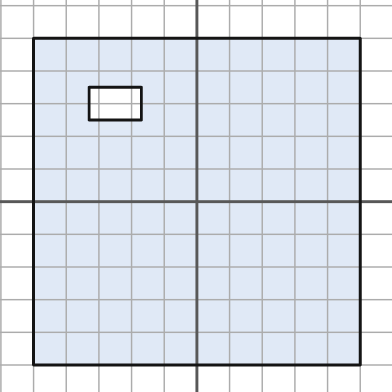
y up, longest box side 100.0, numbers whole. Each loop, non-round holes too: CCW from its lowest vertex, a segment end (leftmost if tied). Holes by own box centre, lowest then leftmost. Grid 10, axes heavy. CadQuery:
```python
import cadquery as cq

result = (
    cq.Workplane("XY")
    .moveTo(-50.0, -50.0)
    .lineTo(50.0, -50.0)
    .lineTo(50.0, 50.0)
    .lineTo(-50.0, 50.0)
    .close()
    .moveTo(-33.0, 25.0)
    .lineTo(-17.0, 25.0)
    .lineTo(-17.0, 35.0)
    .lineTo(-33.0, 35.0)
    .close()
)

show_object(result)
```